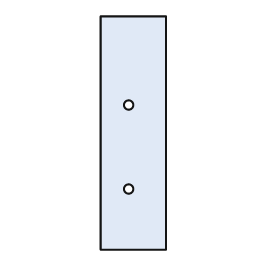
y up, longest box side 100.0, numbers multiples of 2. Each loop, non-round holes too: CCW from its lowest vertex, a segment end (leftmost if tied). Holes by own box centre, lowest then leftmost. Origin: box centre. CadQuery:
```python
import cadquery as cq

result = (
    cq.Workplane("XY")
    .moveTo(-14.0, -50.0)
    .lineTo(14.0, -50.0)
    .lineTo(14.0, 50.0)
    .lineTo(-14.0, 50.0)
    .close()
    .moveTo(-2.0, -24.0)
    .circle(2.0)
    .moveTo(-2.0, 12.0)
    .circle(2.0)
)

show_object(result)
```